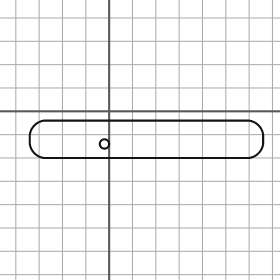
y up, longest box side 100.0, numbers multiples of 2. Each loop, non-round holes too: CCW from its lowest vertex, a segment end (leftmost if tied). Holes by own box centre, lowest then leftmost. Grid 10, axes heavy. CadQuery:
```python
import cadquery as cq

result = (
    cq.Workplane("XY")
    .moveTo(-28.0, -20.0)
    .lineTo(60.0, -20.0)
    .threePointArc((64.0, -18.0), (66.0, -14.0))
    .lineTo(66.0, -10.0)
    .threePointArc((64.0, -6.0), (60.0, -4.0))
    .lineTo(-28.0, -4.0)
    .threePointArc((-32.0, -6.0), (-34.0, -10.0))
    .lineTo(-34.0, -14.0)
    .threePointArc((-32.0, -18.0), (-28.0, -20.0))
    .close()
    .moveTo(-2.0, -14.0)
    .circle(2.0)
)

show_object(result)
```